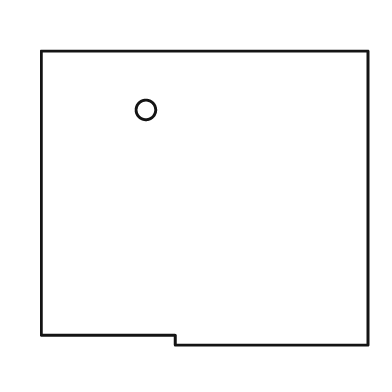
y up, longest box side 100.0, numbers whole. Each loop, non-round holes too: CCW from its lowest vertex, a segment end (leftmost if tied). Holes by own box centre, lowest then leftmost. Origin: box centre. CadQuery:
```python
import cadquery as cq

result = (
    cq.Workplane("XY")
    .moveTo(-9.0, -45.0)
    .lineTo(50.0, -45.0)
    .lineTo(50.0, 45.0)
    .lineTo(-50.0, 45.0)
    .lineTo(-50.0, -42.0)
    .lineTo(-9.0, -42.0)
    .close()
    .moveTo(-18.0, 27.0)
    .circle(3.0)
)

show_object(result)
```